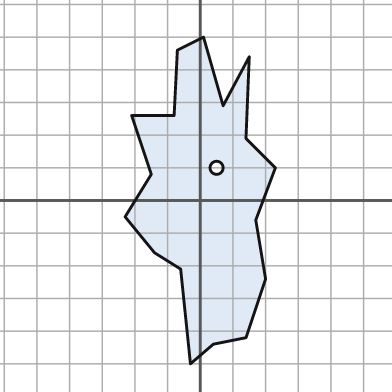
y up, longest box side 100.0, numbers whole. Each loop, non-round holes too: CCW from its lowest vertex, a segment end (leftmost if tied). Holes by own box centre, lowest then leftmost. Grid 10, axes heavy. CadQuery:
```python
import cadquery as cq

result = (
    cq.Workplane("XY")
    .moveTo(-3.0, -50.0)
    .lineTo(4.0, -44.0)
    .lineTo(14.0, -42.0)
    .lineTo(20.0, -24.0)
    .lineTo(17.0, -6.0)
    .lineTo(23.0, 10.0)
    .lineTo(14.0, 19.0)
    .lineTo(15.0, 44.0)
    .lineTo(7.0, 29.0)
    .lineTo(1.0, 50.0)
    .lineTo(-7.0, 46.0)
    .lineTo(-8.0, 26.0)
    .lineTo(-21.0, 26.0)
    .lineTo(-15.0, 8.0)
    .lineTo(-23.0, -5.0)
    .lineTo(-14.0, -16.0)
    .lineTo(-6.0, -21.0)
    .close()
    .moveTo(5.0, 10.0)
    .circle(2.0)
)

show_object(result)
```